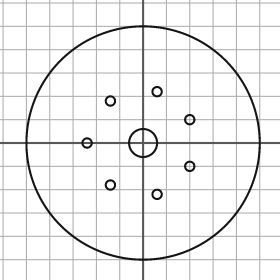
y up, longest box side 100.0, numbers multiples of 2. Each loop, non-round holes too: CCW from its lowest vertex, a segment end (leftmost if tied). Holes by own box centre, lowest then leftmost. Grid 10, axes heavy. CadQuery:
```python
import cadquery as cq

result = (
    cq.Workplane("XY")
    .moveTo(0.0, 0.0)
    .circle(50.0)
    .moveTo(6.0, -22.0)
    .circle(2.0)
    .moveTo(-14.0, -18.0)
    .circle(2.0)
    .moveTo(20.0, -10.0)
    .circle(2.0)
    .moveTo(-24.0, 0.0)
    .circle(2.0)
    .moveTo(0.0, 0.0)
    .circle(6.0)
    .moveTo(20.0, 10.0)
    .circle(2.0)
    .moveTo(-14.0, 18.0)
    .circle(2.0)
    .moveTo(6.0, 22.0)
    .circle(2.0)
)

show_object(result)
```